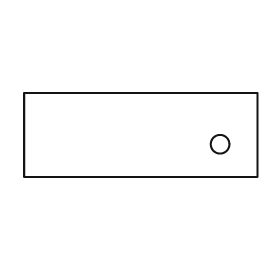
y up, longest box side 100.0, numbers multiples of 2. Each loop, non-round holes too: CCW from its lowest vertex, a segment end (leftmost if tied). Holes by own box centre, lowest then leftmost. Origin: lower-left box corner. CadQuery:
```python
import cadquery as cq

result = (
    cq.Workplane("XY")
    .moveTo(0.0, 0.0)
    .lineTo(100.0, 0.0)
    .lineTo(100.0, 36.0)
    .lineTo(0.0, 36.0)
    .close()
    .moveTo(84.0, 14.0)
    .circle(4.0)
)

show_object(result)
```